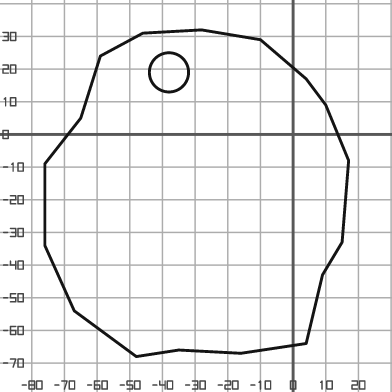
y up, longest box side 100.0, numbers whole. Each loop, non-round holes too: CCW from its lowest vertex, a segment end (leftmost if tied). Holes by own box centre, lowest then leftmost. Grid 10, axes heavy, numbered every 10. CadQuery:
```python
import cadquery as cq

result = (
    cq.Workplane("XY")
    .moveTo(-48.0, -68.0)
    .lineTo(-35.0, -66.0)
    .lineTo(-16.0, -67.0)
    .lineTo(4.0, -64.0)
    .lineTo(9.0, -43.0)
    .lineTo(15.0, -33.0)
    .lineTo(17.0, -8.0)
    .lineTo(10.0, 9.0)
    .lineTo(4.0, 17.0)
    .lineTo(-10.0, 29.0)
    .lineTo(-28.0, 32.0)
    .lineTo(-46.0, 31.0)
    .lineTo(-59.0, 24.0)
    .lineTo(-65.0, 5.0)
    .lineTo(-76.0, -9.0)
    .lineTo(-76.0, -34.0)
    .lineTo(-67.0, -54.0)
    .close()
    .moveTo(-38.0, 19.0)
    .circle(6.0)
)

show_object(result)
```